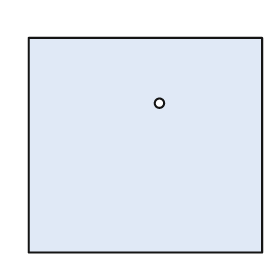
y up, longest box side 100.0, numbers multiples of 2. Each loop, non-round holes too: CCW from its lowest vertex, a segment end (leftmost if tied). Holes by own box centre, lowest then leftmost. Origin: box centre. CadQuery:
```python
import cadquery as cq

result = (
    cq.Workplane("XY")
    .moveTo(-50.0, -46.0)
    .lineTo(50.0, -46.0)
    .lineTo(50.0, 46.0)
    .lineTo(-50.0, 46.0)
    .close()
    .moveTo(6.0, 18.0)
    .circle(2.0)
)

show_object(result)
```